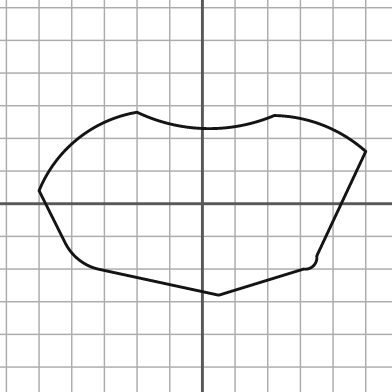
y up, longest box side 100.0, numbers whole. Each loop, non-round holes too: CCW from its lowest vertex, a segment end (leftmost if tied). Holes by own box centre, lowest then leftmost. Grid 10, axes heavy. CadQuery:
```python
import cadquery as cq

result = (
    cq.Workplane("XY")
    .moveTo(5.0, -28.0)
    .lineTo(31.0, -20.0)
    .threePointArc((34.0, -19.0), (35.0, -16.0))
    .lineTo(50.0, 16.0)
    .threePointArc((37.0, 24.0), (22.0, 27.0))
    .threePointArc((1.0, 23.0), (-20.0, 28.0))
    .threePointArc((-38.0, 20.0), (-50.0, 4.0))
    .lineTo(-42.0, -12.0)
    .threePointArc((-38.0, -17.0), (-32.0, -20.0))
    .close()
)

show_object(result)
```